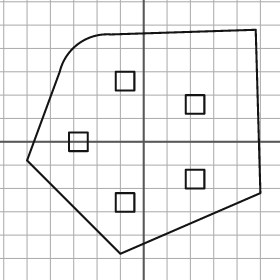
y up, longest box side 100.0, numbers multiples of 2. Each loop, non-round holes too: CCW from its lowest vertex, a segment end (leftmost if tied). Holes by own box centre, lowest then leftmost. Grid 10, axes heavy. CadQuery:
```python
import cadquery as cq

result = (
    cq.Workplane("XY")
    .moveTo(-10.0, -48.0)
    .lineTo(50.0, -22.0)
    .lineTo(48.0, 48.0)
    .lineTo(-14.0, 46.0)
    .threePointArc((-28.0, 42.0), (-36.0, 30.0))
    .lineTo(-50.0, -8.0)
    .close()
    .moveTo(-12.0, -30.0)
    .lineTo(-4.0, -30.0)
    .lineTo(-4.0, -22.0)
    .lineTo(-12.0, -22.0)
    .close()
    .moveTo(18.0, -20.0)
    .lineTo(26.0, -20.0)
    .lineTo(26.0, -12.0)
    .lineTo(18.0, -12.0)
    .close()
    .moveTo(-32.0, -4.0)
    .lineTo(-24.0, -4.0)
    .lineTo(-24.0, 4.0)
    .lineTo(-32.0, 4.0)
    .close()
    .moveTo(18.0, 12.0)
    .lineTo(26.0, 12.0)
    .lineTo(26.0, 20.0)
    .lineTo(18.0, 20.0)
    .close()
    .moveTo(-12.0, 22.0)
    .lineTo(-4.0, 22.0)
    .lineTo(-4.0, 30.0)
    .lineTo(-12.0, 30.0)
    .close()
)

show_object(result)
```